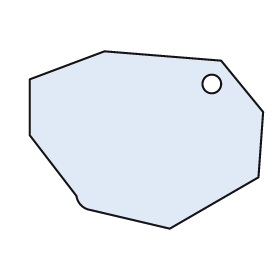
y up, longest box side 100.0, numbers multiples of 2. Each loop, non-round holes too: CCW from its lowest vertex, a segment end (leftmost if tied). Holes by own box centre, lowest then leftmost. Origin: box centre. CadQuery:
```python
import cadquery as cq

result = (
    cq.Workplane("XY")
    .moveTo(10.0, -38.0)
    .lineTo(48.0, -16.0)
    .lineTo(50.0, 12.0)
    .lineTo(32.0, 34.0)
    .lineTo(-18.0, 38.0)
    .lineTo(-50.0, 26.0)
    .lineTo(-50.0, 2.0)
    .lineTo(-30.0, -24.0)
    .threePointArc((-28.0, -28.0), (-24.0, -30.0))
    .close()
    .moveTo(28.0, 24.0)
    .circle(4.0)
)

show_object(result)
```